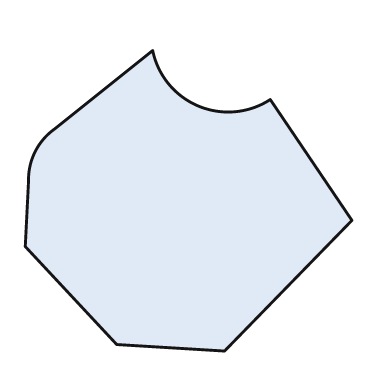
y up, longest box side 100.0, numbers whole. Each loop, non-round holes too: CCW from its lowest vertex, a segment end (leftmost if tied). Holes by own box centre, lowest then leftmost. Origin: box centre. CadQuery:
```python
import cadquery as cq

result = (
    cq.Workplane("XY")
    .moveTo(11.0, -46.0)
    .lineTo(50.0, -6.0)
    .lineTo(25.0, 31.0)
    .threePointArc((3.0, 29.0), (-11.0, 46.0))
    .lineTo(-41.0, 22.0)
    .threePointArc((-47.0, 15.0), (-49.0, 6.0))
    .lineTo(-50.0, -14.0)
    .lineTo(-22.0, -44.0)
    .close()
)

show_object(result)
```